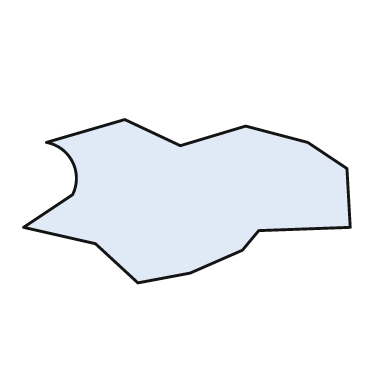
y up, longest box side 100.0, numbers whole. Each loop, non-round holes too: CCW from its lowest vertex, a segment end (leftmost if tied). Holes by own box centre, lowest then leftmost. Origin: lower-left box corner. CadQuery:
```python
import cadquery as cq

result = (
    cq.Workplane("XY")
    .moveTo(35.0, 0.0)
    .lineTo(51.0, 3.0)
    .lineTo(67.0, 10.0)
    .lineTo(72.0, 16.0)
    .lineTo(100.0, 17.0)
    .lineTo(99.0, 35.0)
    .lineTo(87.0, 43.0)
    .lineTo(68.0, 48.0)
    .lineTo(48.0, 42.0)
    .lineTo(31.0, 50.0)
    .lineTo(7.0, 43.0)
    .threePointArc((15.0, 37.0), (15.0, 27.0))
    .lineTo(0.0, 17.0)
    .lineTo(22.0, 12.0)
    .close()
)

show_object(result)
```